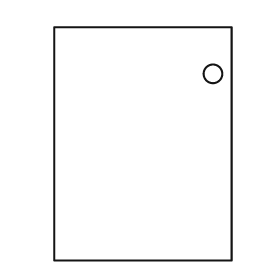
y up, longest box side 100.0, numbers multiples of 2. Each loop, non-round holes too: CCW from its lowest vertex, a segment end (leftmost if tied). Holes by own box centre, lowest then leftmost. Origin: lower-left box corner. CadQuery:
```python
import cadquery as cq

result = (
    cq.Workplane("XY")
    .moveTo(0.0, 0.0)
    .lineTo(76.0, 0.0)
    .lineTo(76.0, 100.0)
    .lineTo(0.0, 100.0)
    .close()
    .moveTo(68.0, 80.0)
    .circle(4.0)
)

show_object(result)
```